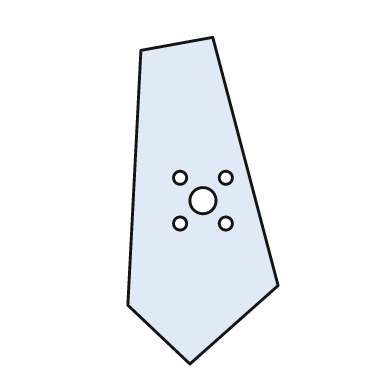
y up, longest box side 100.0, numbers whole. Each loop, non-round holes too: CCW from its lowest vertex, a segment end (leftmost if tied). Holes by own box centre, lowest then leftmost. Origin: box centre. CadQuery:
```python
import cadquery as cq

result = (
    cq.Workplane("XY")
    .moveTo(-4.0, -50.0)
    .lineTo(23.0, -26.0)
    .lineTo(3.0, 50.0)
    .lineTo(-19.0, 46.0)
    .lineTo(-23.0, -32.0)
    .close()
    .moveTo(-7.0, -7.0)
    .circle(2.0)
    .moveTo(7.0, -7.0)
    .circle(2.0)
    .moveTo(0.0, 0.0)
    .circle(4.0)
    .moveTo(-7.0, 7.0)
    .circle(2.0)
    .moveTo(7.0, 7.0)
    .circle(2.0)
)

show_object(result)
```